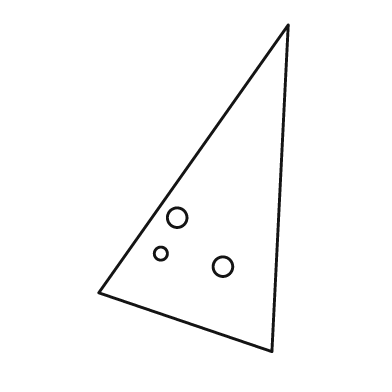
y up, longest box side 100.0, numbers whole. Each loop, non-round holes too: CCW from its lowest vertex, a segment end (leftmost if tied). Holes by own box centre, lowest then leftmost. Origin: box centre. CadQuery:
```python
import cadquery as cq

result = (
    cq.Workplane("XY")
    .moveTo(24.0, -50.0)
    .lineTo(29.0, 50.0)
    .lineTo(-29.0, -32.0)
    .close()
    .moveTo(9.0, -24.0)
    .circle(3.0)
    .moveTo(-10.0, -20.0)
    .circle(2.0)
    .moveTo(-5.0, -9.0)
    .circle(3.0)
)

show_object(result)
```